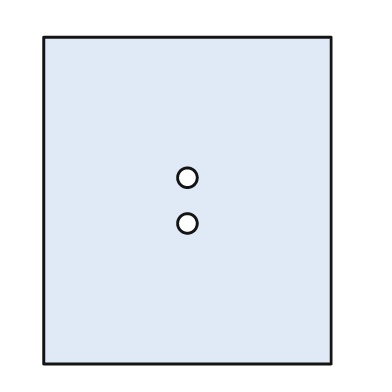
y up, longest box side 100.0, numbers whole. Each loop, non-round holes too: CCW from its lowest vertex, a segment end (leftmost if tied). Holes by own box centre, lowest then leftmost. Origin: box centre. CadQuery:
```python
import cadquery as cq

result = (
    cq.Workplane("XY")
    .moveTo(-44.0, -50.0)
    .lineTo(44.0, -50.0)
    .lineTo(44.0, 50.0)
    .lineTo(-44.0, 50.0)
    .close()
    .moveTo(0.0, -7.0)
    .circle(3.0)
    .moveTo(0.0, 7.0)
    .circle(3.0)
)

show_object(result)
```